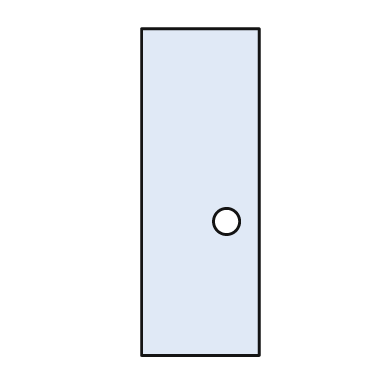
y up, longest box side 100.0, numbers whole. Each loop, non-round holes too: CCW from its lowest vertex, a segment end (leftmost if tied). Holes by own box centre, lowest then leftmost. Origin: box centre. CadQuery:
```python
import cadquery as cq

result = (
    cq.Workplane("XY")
    .moveTo(-18.0, -50.0)
    .lineTo(18.0, -50.0)
    .lineTo(18.0, 50.0)
    .lineTo(-18.0, 50.0)
    .close()
    .moveTo(8.0, -9.0)
    .circle(4.0)
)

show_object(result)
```